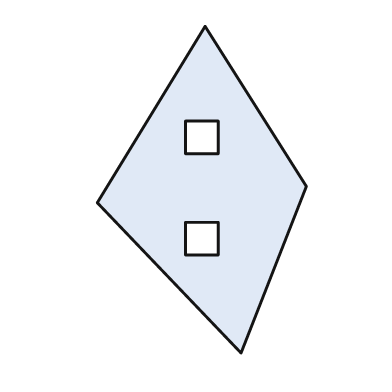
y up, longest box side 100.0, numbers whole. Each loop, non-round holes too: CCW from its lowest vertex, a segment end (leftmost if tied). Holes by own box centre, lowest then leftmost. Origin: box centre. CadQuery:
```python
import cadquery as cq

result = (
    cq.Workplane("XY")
    .moveTo(12.0, -50.0)
    .lineTo(32.0, 1.0)
    .lineTo(1.0, 50.0)
    .lineTo(-32.0, -4.0)
    .close()
    .moveTo(-5.0, -20.0)
    .lineTo(5.0, -20.0)
    .lineTo(5.0, -10.0)
    .lineTo(-5.0, -10.0)
    .close()
    .moveTo(-5.0, 11.0)
    .lineTo(5.0, 11.0)
    .lineTo(5.0, 21.0)
    .lineTo(-5.0, 21.0)
    .close()
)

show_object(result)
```